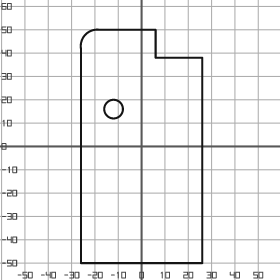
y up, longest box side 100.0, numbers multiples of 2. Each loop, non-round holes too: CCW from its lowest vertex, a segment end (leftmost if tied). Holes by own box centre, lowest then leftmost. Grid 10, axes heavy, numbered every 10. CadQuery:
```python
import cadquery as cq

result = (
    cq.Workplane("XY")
    .moveTo(-26.0, -50.0)
    .lineTo(26.0, -50.0)
    .lineTo(26.0, 38.0)
    .lineTo(6.0, 38.0)
    .lineTo(6.0, 50.0)
    .lineTo(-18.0, 50.0)
    .threePointArc((-24.0, 48.0), (-26.0, 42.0))
    .close()
    .moveTo(-12.0, 16.0)
    .circle(4.0)
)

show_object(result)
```